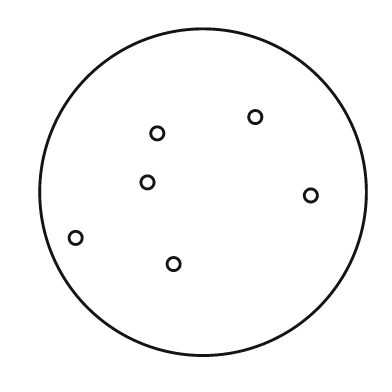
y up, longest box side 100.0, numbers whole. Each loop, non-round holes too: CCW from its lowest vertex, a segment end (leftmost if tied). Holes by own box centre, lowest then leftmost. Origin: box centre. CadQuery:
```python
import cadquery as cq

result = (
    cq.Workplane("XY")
    .moveTo(0.0, 0.0)
    .circle(50.0)
    .moveTo(-9.0, -22.0)
    .circle(2.0)
    .moveTo(-39.0, -14.0)
    .circle(2.0)
    .moveTo(33.0, -1.0)
    .circle(2.0)
    .moveTo(-17.0, 3.0)
    .circle(2.0)
    .moveTo(-14.0, 18.0)
    .circle(2.0)
    .moveTo(16.0, 23.0)
    .circle(2.0)
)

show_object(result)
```